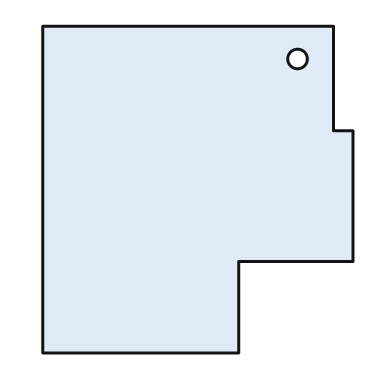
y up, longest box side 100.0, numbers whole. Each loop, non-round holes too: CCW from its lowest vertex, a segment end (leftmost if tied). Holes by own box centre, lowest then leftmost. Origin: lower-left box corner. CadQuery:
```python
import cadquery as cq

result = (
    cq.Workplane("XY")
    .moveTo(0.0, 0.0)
    .lineTo(60.0, 0.0)
    .lineTo(60.0, 28.0)
    .lineTo(95.0, 28.0)
    .lineTo(95.0, 68.0)
    .lineTo(89.0, 68.0)
    .lineTo(89.0, 100.0)
    .lineTo(0.0, 100.0)
    .close()
    .moveTo(78.0, 90.0)
    .circle(3.0)
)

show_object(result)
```